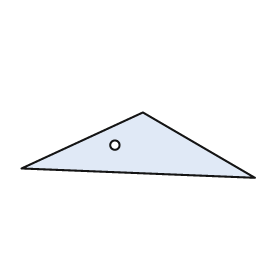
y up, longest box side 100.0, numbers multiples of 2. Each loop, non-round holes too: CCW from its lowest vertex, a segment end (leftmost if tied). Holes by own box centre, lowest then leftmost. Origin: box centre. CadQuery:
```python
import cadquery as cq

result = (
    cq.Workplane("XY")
    .moveTo(50.0, -14.0)
    .lineTo(2.0, 14.0)
    .lineTo(-50.0, -10.0)
    .close()
    .moveTo(-10.0, 0.0)
    .circle(2.0)
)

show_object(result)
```